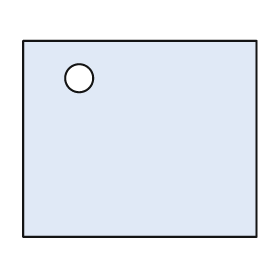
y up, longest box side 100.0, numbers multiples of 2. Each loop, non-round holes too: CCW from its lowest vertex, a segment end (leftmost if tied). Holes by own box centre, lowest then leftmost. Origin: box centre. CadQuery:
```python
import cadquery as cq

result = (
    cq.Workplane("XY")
    .moveTo(-50.0, -42.0)
    .lineTo(50.0, -42.0)
    .lineTo(50.0, 42.0)
    .lineTo(-50.0, 42.0)
    .close()
    .moveTo(-26.0, 26.0)
    .circle(6.0)
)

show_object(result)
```